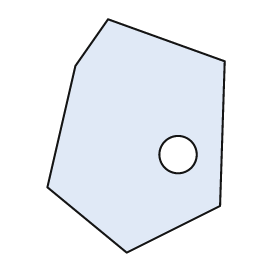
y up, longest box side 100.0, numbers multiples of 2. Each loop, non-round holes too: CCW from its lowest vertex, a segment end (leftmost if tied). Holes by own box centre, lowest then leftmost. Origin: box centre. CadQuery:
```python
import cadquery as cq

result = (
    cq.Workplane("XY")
    .moveTo(-4.0, -50.0)
    .lineTo(36.0, -30.0)
    .lineTo(38.0, 32.0)
    .lineTo(-12.0, 50.0)
    .lineTo(-26.0, 30.0)
    .lineTo(-38.0, -22.0)
    .close()
    .moveTo(18.0, -8.0)
    .circle(8.0)
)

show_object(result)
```